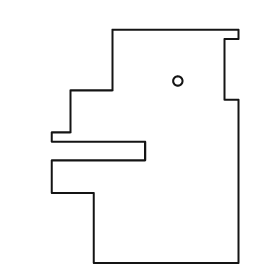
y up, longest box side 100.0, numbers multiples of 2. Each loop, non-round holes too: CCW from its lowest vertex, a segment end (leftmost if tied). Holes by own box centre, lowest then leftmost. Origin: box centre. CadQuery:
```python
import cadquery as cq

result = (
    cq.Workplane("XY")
    .moveTo(-22.0, -50.0)
    .lineTo(40.0, -50.0)
    .lineTo(40.0, 20.0)
    .lineTo(34.0, 20.0)
    .lineTo(34.0, 46.0)
    .lineTo(40.0, 46.0)
    .lineTo(40.0, 50.0)
    .lineTo(-14.0, 50.0)
    .lineTo(-14.0, 24.0)
    .lineTo(-32.0, 24.0)
    .lineTo(-32.0, 6.0)
    .lineTo(-40.0, 6.0)
    .lineTo(-40.0, 2.0)
    .lineTo(0.0, 2.0)
    .lineTo(0.0, -6.0)
    .lineTo(-40.0, -6.0)
    .lineTo(-40.0, -20.0)
    .lineTo(-22.0, -20.0)
    .close()
    .moveTo(14.0, 28.0)
    .circle(2.0)
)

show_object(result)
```